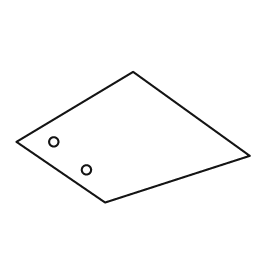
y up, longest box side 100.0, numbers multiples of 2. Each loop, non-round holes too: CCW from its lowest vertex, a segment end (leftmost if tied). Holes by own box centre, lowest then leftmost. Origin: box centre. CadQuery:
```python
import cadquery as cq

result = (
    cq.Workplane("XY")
    .moveTo(-12.0, -28.0)
    .lineTo(50.0, -8.0)
    .lineTo(0.0, 28.0)
    .lineTo(-50.0, -2.0)
    .close()
    .moveTo(-20.0, -14.0)
    .circle(2.0)
    .moveTo(-34.0, -2.0)
    .circle(2.0)
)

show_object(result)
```